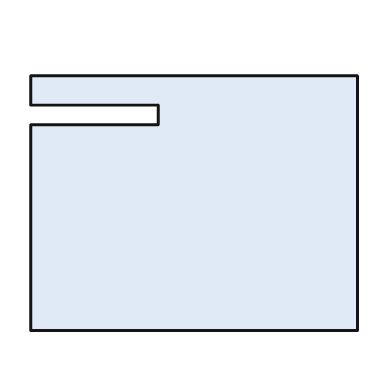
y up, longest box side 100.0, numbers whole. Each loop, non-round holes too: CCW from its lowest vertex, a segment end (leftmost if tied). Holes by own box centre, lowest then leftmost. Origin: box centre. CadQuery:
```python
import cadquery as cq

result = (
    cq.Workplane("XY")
    .moveTo(-50.0, -39.0)
    .lineTo(50.0, -39.0)
    .lineTo(50.0, 39.0)
    .lineTo(-50.0, 39.0)
    .lineTo(-50.0, 30.0)
    .lineTo(-11.0, 30.0)
    .lineTo(-11.0, 24.0)
    .lineTo(-50.0, 24.0)
    .close()
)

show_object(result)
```